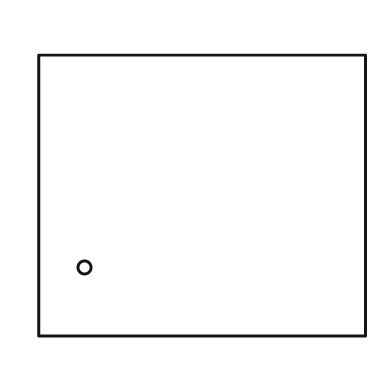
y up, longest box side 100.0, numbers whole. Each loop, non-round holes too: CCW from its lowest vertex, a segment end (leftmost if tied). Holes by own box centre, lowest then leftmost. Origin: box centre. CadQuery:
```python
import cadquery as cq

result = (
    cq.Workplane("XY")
    .moveTo(-50.0, -43.0)
    .lineTo(50.0, -43.0)
    .lineTo(50.0, 43.0)
    .lineTo(-50.0, 43.0)
    .close()
    .moveTo(-36.0, -22.0)
    .circle(2.0)
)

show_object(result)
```